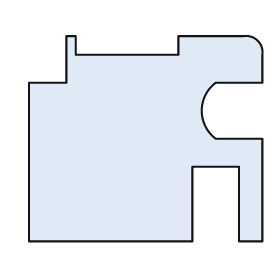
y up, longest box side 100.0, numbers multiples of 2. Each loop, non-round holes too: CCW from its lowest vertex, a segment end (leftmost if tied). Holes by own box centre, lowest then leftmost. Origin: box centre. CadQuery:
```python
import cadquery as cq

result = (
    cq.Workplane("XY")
    .moveTo(-50.0, -44.0)
    .lineTo(20.0, -44.0)
    .lineTo(20.0, -12.0)
    .lineTo(40.0, -12.0)
    .lineTo(40.0, -44.0)
    .lineTo(50.0, -44.0)
    .lineTo(50.0, 0.0)
    .lineTo(30.0, 0.0)
    .threePointArc((24.0, 12.0), (30.0, 24.0))
    .lineTo(50.0, 24.0)
    .lineTo(50.0, 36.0)
    .threePointArc((48.0, 42.0), (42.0, 44.0))
    .lineTo(14.0, 44.0)
    .lineTo(14.0, 36.0)
    .lineTo(-30.0, 36.0)
    .lineTo(-30.0, 44.0)
    .lineTo(-34.0, 44.0)
    .lineTo(-34.0, 24.0)
    .lineTo(-50.0, 24.0)
    .close()
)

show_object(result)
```